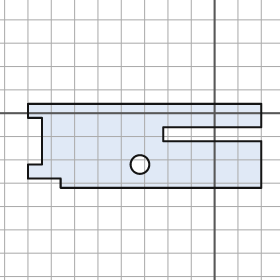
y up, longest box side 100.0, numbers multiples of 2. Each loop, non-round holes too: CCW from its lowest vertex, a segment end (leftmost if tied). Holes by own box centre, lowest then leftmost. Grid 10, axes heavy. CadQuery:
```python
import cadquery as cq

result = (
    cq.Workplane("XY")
    .moveTo(-66.0, -32.0)
    .lineTo(20.0, -32.0)
    .lineTo(20.0, -12.0)
    .lineTo(-22.0, -12.0)
    .lineTo(-22.0, -6.0)
    .lineTo(20.0, -6.0)
    .lineTo(20.0, 4.0)
    .lineTo(-80.0, 4.0)
    .lineTo(-80.0, -2.0)
    .lineTo(-74.0, -2.0)
    .lineTo(-74.0, -22.0)
    .lineTo(-80.0, -22.0)
    .lineTo(-80.0, -28.0)
    .lineTo(-66.0, -28.0)
    .close()
    .moveTo(-32.0, -22.0)
    .circle(4.0)
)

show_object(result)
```